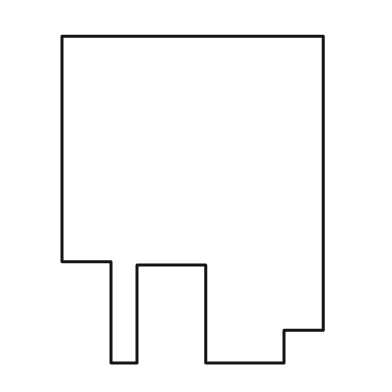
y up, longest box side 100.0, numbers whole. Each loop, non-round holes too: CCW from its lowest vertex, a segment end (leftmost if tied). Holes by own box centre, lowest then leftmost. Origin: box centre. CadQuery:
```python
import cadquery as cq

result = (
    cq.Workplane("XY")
    .moveTo(-25.0, -50.0)
    .lineTo(-17.0, -50.0)
    .lineTo(-17.0, -20.0)
    .lineTo(4.0, -20.0)
    .lineTo(4.0, -50.0)
    .lineTo(28.0, -50.0)
    .lineTo(28.0, -40.0)
    .lineTo(40.0, -40.0)
    .lineTo(40.0, 50.0)
    .lineTo(-40.0, 50.0)
    .lineTo(-40.0, -19.0)
    .lineTo(-25.0, -19.0)
    .close()
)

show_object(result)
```